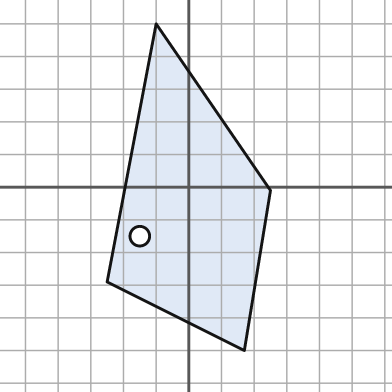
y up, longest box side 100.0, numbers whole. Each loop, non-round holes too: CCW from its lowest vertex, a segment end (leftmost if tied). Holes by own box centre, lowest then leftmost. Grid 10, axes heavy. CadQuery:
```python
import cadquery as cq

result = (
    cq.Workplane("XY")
    .moveTo(17.0, -50.0)
    .lineTo(25.0, -1.0)
    .lineTo(-10.0, 50.0)
    .lineTo(-25.0, -29.0)
    .close()
    .moveTo(-15.0, -15.0)
    .circle(3.0)
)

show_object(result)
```